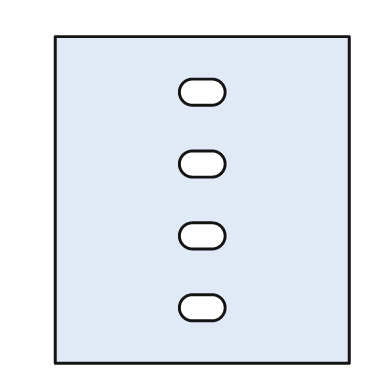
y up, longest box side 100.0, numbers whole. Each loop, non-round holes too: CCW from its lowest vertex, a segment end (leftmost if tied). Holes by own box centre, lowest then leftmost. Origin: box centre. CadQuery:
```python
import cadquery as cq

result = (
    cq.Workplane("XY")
    .moveTo(-45.0, -50.0)
    .lineTo(45.0, -50.0)
    .lineTo(45.0, 50.0)
    .lineTo(-45.0, 50.0)
    .close()
    .moveTo(-3.0, -37.0)
    .lineTo(3.0, -37.0)
    .threePointArc((7.0, -33.0), (3.0, -29.0))
    .lineTo(-3.0, -29.0)
    .threePointArc((-7.0, -33.0), (-3.0, -37.0))
    .close()
    .moveTo(-3.0, -15.0)
    .lineTo(3.0, -15.0)
    .threePointArc((7.0, -11.0), (3.0, -7.0))
    .lineTo(-3.0, -7.0)
    .threePointArc((-7.0, -11.0), (-3.0, -15.0))
    .close()
    .moveTo(-3.0, 7.0)
    .lineTo(3.0, 7.0)
    .threePointArc((7.0, 11.0), (3.0, 15.0))
    .lineTo(-3.0, 15.0)
    .threePointArc((-7.0, 11.0), (-3.0, 7.0))
    .close()
    .moveTo(-3.0, 29.0)
    .lineTo(3.0, 29.0)
    .threePointArc((7.0, 33.0), (3.0, 37.0))
    .lineTo(-3.0, 37.0)
    .threePointArc((-7.0, 33.0), (-3.0, 29.0))
    .close()
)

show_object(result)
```